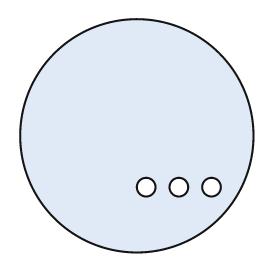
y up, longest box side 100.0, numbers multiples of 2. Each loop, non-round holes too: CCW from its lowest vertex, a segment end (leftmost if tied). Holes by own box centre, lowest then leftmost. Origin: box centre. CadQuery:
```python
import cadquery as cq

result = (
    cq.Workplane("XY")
    .moveTo(0.0, 0.0)
    .circle(50.0)
    .moveTo(4.0, -22.0)
    .circle(4.0)
    .moveTo(18.0, -22.0)
    .circle(4.0)
    .moveTo(32.0, -22.0)
    .circle(4.0)
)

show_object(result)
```